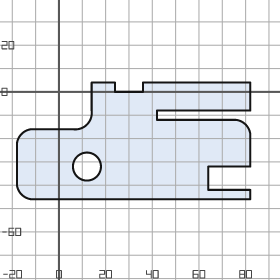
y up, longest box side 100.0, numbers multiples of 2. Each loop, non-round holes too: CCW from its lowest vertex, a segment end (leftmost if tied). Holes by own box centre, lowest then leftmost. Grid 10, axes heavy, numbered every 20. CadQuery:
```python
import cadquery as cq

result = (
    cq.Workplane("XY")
    .moveTo(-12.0, -46.0)
    .lineTo(82.0, -46.0)
    .lineTo(82.0, -42.0)
    .lineTo(64.0, -42.0)
    .lineTo(64.0, -32.0)
    .lineTo(82.0, -32.0)
    .lineTo(82.0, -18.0)
    .threePointArc((80.0, -14.0), (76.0, -12.0))
    .lineTo(42.0, -12.0)
    .lineTo(42.0, -8.0)
    .lineTo(82.0, -8.0)
    .lineTo(82.0, 4.0)
    .lineTo(36.0, 4.0)
    .lineTo(36.0, 0.0)
    .lineTo(24.0, 0.0)
    .lineTo(24.0, 4.0)
    .lineTo(14.0, 4.0)
    .lineTo(14.0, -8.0)
    .threePointArc((12.0, -14.0), (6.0, -16.0))
    .lineTo(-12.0, -16.0)
    .threePointArc((-16.0, -18.0), (-18.0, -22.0))
    .lineTo(-18.0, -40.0)
    .threePointArc((-16.0, -44.0), (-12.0, -46.0))
    .close()
    .moveTo(12.0, -32.0)
    .circle(6.0)
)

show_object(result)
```